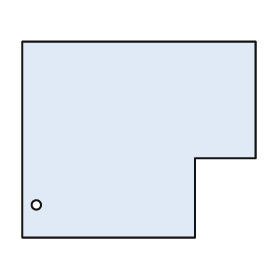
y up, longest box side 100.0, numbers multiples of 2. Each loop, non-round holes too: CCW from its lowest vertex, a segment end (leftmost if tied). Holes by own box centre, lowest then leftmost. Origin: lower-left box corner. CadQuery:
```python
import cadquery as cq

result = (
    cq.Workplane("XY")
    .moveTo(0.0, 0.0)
    .lineTo(74.0, 0.0)
    .lineTo(74.0, 34.0)
    .lineTo(100.0, 34.0)
    .lineTo(100.0, 84.0)
    .lineTo(0.0, 84.0)
    .close()
    .moveTo(6.0, 14.0)
    .circle(2.0)
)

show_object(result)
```